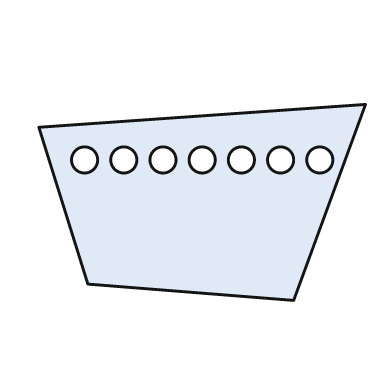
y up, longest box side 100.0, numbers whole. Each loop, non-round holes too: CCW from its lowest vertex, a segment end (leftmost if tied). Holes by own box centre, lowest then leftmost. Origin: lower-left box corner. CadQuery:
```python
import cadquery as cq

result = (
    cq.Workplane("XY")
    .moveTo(78.0, 0.0)
    .lineTo(100.0, 60.0)
    .lineTo(0.0, 53.0)
    .lineTo(15.0, 5.0)
    .close()
    .moveTo(14.0, 43.0)
    .circle(4.0)
    .moveTo(26.0, 43.0)
    .circle(4.0)
    .moveTo(38.0, 43.0)
    .circle(4.0)
    .moveTo(50.0, 43.0)
    .circle(4.0)
    .moveTo(62.0, 43.0)
    .circle(4.0)
    .moveTo(74.0, 43.0)
    .circle(4.0)
    .moveTo(86.0, 43.0)
    .circle(4.0)
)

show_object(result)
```